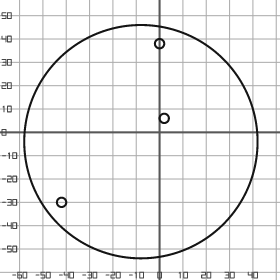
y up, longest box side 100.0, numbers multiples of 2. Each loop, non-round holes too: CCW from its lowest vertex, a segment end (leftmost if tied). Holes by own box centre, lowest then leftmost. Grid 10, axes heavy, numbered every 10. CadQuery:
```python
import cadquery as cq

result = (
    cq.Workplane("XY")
    .moveTo(-8.0, -4.0)
    .circle(50.0)
    .moveTo(-42.0, -30.0)
    .circle(2.0)
    .moveTo(2.0, 6.0)
    .circle(2.0)
    .moveTo(0.0, 38.0)
    .circle(2.0)
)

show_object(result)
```